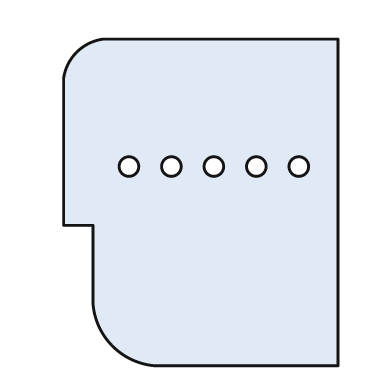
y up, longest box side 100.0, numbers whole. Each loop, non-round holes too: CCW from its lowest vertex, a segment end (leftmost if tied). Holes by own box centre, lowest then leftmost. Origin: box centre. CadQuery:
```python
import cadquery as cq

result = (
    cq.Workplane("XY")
    .moveTo(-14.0, -50.0)
    .lineTo(42.0, -50.0)
    .lineTo(42.0, 50.0)
    .lineTo(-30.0, 50.0)
    .threePointArc((-38.0, 46.0), (-42.0, 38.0))
    .lineTo(-42.0, -7.0)
    .lineTo(-33.0, -7.0)
    .lineTo(-33.0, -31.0)
    .threePointArc((-27.0, -44.0), (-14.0, -50.0))
    .close()
    .moveTo(-22.0, 11.0)
    .circle(3.0)
    .moveTo(-9.0, 11.0)
    .circle(3.0)
    .moveTo(4.0, 11.0)
    .circle(3.0)
    .moveTo(17.0, 11.0)
    .circle(3.0)
    .moveTo(30.0, 11.0)
    .circle(3.0)
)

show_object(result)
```